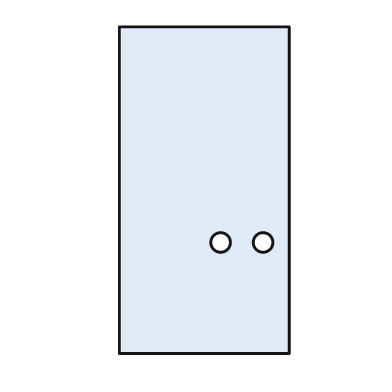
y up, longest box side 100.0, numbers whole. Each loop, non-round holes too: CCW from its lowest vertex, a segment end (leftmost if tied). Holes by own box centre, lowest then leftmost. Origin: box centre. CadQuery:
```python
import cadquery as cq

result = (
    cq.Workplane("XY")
    .moveTo(-26.0, -50.0)
    .lineTo(26.0, -50.0)
    .lineTo(26.0, 50.0)
    .lineTo(-26.0, 50.0)
    .close()
    .moveTo(5.0, -16.0)
    .circle(3.0)
    .moveTo(18.0, -16.0)
    .circle(3.0)
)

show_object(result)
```